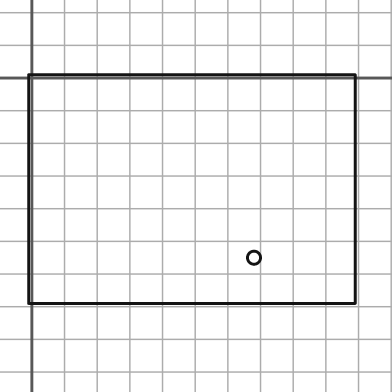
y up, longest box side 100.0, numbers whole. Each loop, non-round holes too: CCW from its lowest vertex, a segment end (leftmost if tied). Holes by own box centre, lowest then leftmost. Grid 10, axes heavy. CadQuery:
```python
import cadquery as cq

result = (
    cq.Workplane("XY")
    .moveTo(-1.0, -69.0)
    .lineTo(99.0, -69.0)
    .lineTo(99.0, 1.0)
    .lineTo(-1.0, 1.0)
    .close()
    .moveTo(68.0, -55.0)
    .circle(2.0)
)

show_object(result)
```